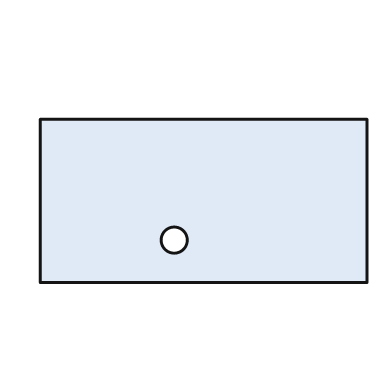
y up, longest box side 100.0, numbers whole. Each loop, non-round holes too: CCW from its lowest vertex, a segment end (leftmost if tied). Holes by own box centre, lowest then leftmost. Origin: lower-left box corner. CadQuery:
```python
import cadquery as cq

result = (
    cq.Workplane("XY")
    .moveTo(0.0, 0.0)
    .lineTo(100.0, 0.0)
    .lineTo(100.0, 50.0)
    .lineTo(0.0, 50.0)
    .close()
    .moveTo(41.0, 13.0)
    .circle(4.0)
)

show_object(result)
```